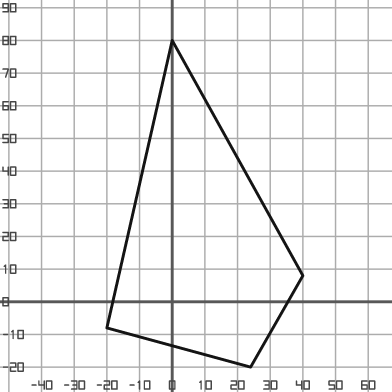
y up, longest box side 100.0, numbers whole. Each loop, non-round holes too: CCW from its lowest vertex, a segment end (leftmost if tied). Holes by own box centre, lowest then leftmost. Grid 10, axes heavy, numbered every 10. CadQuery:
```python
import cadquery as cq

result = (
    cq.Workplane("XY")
    .moveTo(24.0, -20.0)
    .lineTo(40.0, 8.0)
    .lineTo(0.0, 80.0)
    .lineTo(-20.0, -8.0)
    .close()
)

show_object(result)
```